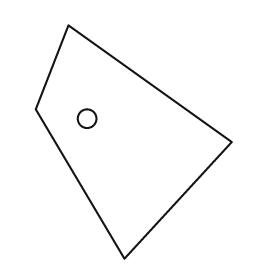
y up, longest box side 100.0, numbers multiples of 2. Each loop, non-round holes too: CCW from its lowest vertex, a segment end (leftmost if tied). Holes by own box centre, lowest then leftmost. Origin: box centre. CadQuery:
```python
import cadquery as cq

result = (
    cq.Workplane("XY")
    .moveTo(-4.0, -50.0)
    .lineTo(42.0, 0.0)
    .lineTo(-28.0, 50.0)
    .lineTo(-42.0, 14.0)
    .close()
    .moveTo(-20.0, 10.0)
    .circle(4.0)
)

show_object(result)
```